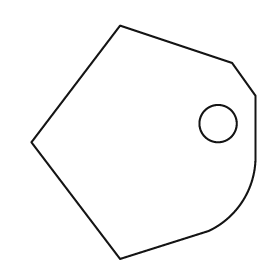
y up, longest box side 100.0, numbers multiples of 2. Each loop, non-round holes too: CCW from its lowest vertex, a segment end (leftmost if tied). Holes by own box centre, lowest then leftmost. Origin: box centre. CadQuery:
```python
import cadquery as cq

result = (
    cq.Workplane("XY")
    .moveTo(-10.0, -50.0)
    .lineTo(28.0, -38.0)
    .threePointArc((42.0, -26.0), (48.0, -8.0))
    .lineTo(48.0, 20.0)
    .lineTo(38.0, 34.0)
    .lineTo(-10.0, 50.0)
    .lineTo(-48.0, 0.0)
    .close()
    .moveTo(32.0, 8.0)
    .circle(8.0)
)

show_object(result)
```